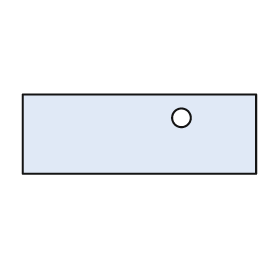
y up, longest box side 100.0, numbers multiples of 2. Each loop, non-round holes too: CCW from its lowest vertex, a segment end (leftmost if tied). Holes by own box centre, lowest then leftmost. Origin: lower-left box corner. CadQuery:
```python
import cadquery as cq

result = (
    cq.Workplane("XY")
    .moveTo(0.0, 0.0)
    .lineTo(100.0, 0.0)
    .lineTo(100.0, 34.0)
    .lineTo(0.0, 34.0)
    .close()
    .moveTo(68.0, 24.0)
    .circle(4.0)
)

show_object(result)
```